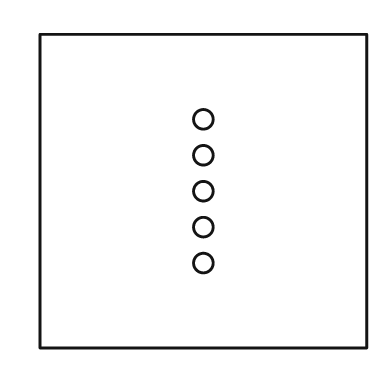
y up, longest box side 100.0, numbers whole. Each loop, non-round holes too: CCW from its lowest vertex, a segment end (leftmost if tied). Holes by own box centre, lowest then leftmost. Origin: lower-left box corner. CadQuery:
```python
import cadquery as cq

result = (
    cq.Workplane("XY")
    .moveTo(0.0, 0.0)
    .lineTo(100.0, 0.0)
    .lineTo(100.0, 96.0)
    .lineTo(0.0, 96.0)
    .close()
    .moveTo(50.0, 26.0)
    .circle(3.0)
    .moveTo(50.0, 37.0)
    .circle(3.0)
    .moveTo(50.0, 48.0)
    .circle(3.0)
    .moveTo(50.0, 59.0)
    .circle(3.0)
    .moveTo(50.0, 70.0)
    .circle(3.0)
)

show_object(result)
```